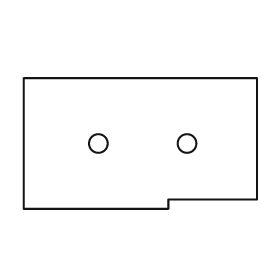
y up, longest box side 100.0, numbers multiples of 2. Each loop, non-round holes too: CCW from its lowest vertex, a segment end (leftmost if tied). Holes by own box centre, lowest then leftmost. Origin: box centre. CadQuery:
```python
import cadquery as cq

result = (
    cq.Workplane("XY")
    .moveTo(-50.0, -28.0)
    .lineTo(12.0, -28.0)
    .lineTo(12.0, -24.0)
    .lineTo(50.0, -24.0)
    .lineTo(50.0, 28.0)
    .lineTo(-50.0, 28.0)
    .close()
    .moveTo(-18.0, 0.0)
    .circle(4.0)
    .moveTo(20.0, 0.0)
    .circle(4.0)
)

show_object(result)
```